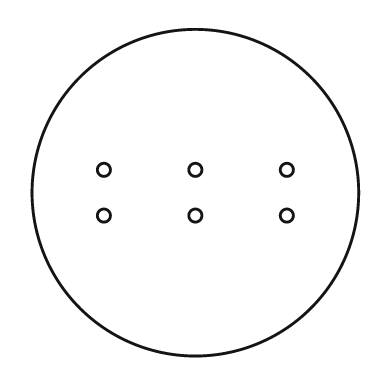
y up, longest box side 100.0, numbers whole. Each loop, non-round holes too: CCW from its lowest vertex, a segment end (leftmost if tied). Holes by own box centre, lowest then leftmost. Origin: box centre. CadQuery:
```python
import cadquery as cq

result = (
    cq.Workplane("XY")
    .moveTo(0.0, 0.0)
    .circle(50.0)
    .moveTo(-28.0, -7.0)
    .circle(2.0)
    .moveTo(0.0, -7.0)
    .circle(2.0)
    .moveTo(28.0, -7.0)
    .circle(2.0)
    .moveTo(-28.0, 7.0)
    .circle(2.0)
    .moveTo(0.0, 7.0)
    .circle(2.0)
    .moveTo(28.0, 7.0)
    .circle(2.0)
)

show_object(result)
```